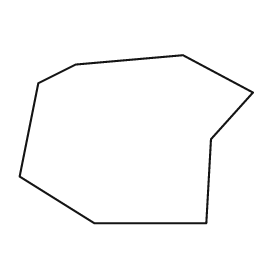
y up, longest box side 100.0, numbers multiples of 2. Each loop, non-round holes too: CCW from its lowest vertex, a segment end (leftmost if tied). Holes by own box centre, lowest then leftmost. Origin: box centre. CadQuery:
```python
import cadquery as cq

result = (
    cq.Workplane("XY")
    .moveTo(-18.0, -36.0)
    .lineTo(30.0, -36.0)
    .lineTo(32.0, 0.0)
    .lineTo(50.0, 20.0)
    .lineTo(20.0, 36.0)
    .lineTo(-26.0, 32.0)
    .lineTo(-42.0, 24.0)
    .lineTo(-50.0, -16.0)
    .close()
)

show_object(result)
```